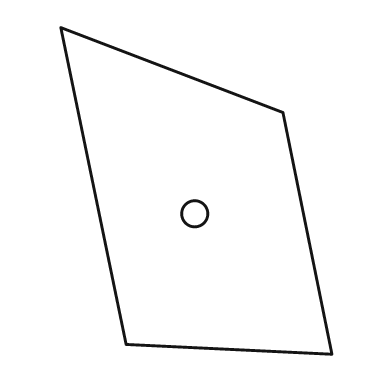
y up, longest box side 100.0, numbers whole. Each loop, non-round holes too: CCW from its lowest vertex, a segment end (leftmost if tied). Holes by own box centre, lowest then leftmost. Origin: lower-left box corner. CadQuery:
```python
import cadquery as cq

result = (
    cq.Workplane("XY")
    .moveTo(83.0, 0.0)
    .lineTo(68.0, 74.0)
    .lineTo(0.0, 100.0)
    .lineTo(20.0, 3.0)
    .close()
    .moveTo(41.0, 43.0)
    .circle(4.0)
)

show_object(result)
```